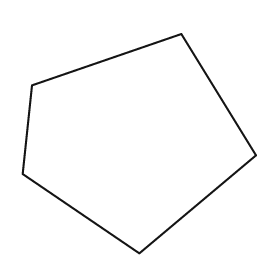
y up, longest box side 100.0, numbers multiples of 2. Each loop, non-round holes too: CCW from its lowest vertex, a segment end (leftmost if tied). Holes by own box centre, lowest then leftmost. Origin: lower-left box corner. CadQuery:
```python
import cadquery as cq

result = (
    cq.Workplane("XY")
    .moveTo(50.0, 0.0)
    .lineTo(100.0, 42.0)
    .lineTo(68.0, 94.0)
    .lineTo(4.0, 72.0)
    .lineTo(0.0, 34.0)
    .close()
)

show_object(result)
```